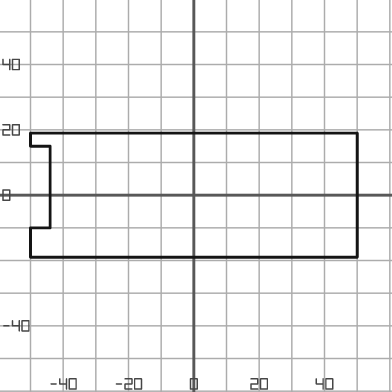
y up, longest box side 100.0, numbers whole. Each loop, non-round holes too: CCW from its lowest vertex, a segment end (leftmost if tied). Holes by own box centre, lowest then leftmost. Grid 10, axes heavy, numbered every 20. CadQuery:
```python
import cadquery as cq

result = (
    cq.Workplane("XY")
    .moveTo(-50.0, -19.0)
    .lineTo(50.0, -19.0)
    .lineTo(50.0, 19.0)
    .lineTo(-50.0, 19.0)
    .lineTo(-50.0, 15.0)
    .lineTo(-44.0, 15.0)
    .lineTo(-44.0, -10.0)
    .lineTo(-50.0, -10.0)
    .close()
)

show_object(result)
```